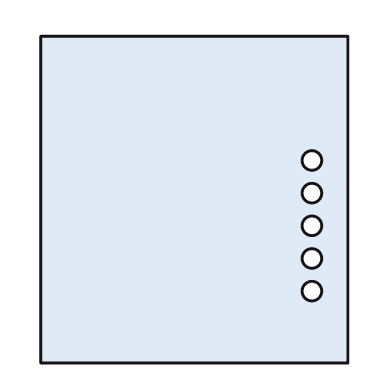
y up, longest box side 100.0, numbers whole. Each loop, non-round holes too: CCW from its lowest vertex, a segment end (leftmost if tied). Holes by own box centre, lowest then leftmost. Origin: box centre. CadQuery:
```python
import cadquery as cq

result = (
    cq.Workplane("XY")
    .moveTo(-47.0, -50.0)
    .lineTo(47.0, -50.0)
    .lineTo(47.0, 50.0)
    .lineTo(-47.0, 50.0)
    .close()
    .moveTo(36.0, -28.0)
    .circle(3.0)
    .moveTo(36.0, -18.0)
    .circle(3.0)
    .moveTo(36.0, -8.0)
    .circle(3.0)
    .moveTo(36.0, 2.0)
    .circle(3.0)
    .moveTo(36.0, 12.0)
    .circle(3.0)
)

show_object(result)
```